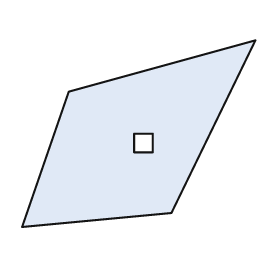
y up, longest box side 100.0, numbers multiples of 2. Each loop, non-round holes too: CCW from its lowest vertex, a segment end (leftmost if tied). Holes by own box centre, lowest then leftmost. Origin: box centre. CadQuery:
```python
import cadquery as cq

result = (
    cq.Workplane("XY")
    .moveTo(-50.0, -40.0)
    .lineTo(14.0, -34.0)
    .lineTo(50.0, 40.0)
    .lineTo(-30.0, 18.0)
    .close()
    .moveTo(-2.0, -8.0)
    .lineTo(6.0, -8.0)
    .lineTo(6.0, 0.0)
    .lineTo(-2.0, 0.0)
    .close()
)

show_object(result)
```